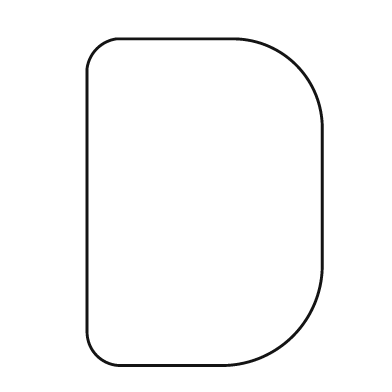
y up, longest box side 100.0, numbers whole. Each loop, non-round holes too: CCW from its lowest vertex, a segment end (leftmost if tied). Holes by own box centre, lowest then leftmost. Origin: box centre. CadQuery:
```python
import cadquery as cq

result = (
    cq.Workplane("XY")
    .moveTo(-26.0, -50.0)
    .lineTo(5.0, -50.0)
    .threePointArc((27.0, -41.0), (36.0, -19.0))
    .lineTo(36.0, 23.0)
    .threePointArc((28.0, 42.0), (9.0, 50.0))
    .lineTo(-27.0, 50.0)
    .threePointArc((-33.0, 47.0), (-36.0, 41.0))
    .lineTo(-36.0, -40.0)
    .threePointArc((-33.0, -47.0), (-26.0, -50.0))
    .close()
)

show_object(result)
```